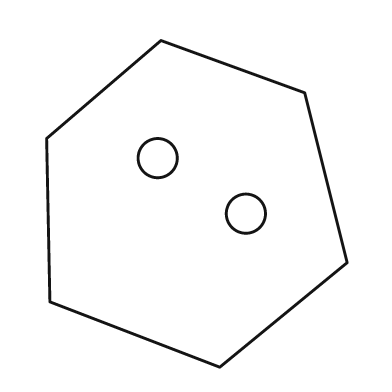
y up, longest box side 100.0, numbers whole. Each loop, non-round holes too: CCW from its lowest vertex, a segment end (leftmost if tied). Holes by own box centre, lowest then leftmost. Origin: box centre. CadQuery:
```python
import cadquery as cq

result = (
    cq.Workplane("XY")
    .moveTo(7.0, -50.0)
    .lineTo(46.0, -18.0)
    .lineTo(33.0, 34.0)
    .lineTo(-11.0, 50.0)
    .lineTo(-46.0, 20.0)
    .lineTo(-45.0, -30.0)
    .close()
    .moveTo(15.0, -3.0)
    .circle(6.0)
    .moveTo(-12.0, 14.0)
    .circle(6.0)
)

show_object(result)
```